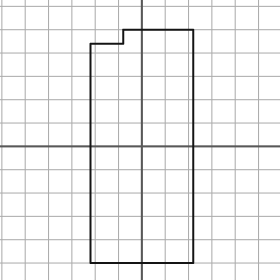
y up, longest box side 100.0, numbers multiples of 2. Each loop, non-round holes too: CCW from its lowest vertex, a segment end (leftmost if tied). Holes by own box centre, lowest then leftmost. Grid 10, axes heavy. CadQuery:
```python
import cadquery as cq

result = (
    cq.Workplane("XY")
    .moveTo(-22.0, -50.0)
    .lineTo(22.0, -50.0)
    .lineTo(22.0, 50.0)
    .lineTo(-8.0, 50.0)
    .lineTo(-8.0, 44.0)
    .lineTo(-22.0, 44.0)
    .close()
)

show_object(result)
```